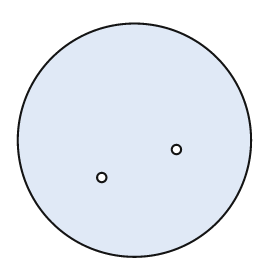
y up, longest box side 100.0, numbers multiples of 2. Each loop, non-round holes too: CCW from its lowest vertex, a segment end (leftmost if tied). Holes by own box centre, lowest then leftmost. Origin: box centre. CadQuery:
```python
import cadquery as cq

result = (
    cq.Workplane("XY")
    .moveTo(0.0, 0.0)
    .circle(50.0)
    .moveTo(-14.0, -16.0)
    .circle(2.0)
    .moveTo(18.0, -4.0)
    .circle(2.0)
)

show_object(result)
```